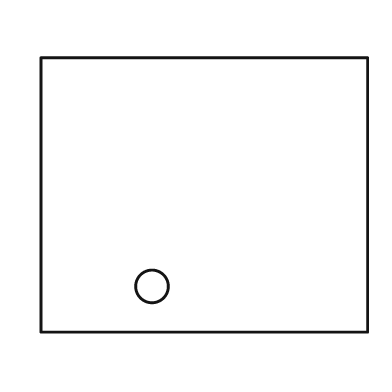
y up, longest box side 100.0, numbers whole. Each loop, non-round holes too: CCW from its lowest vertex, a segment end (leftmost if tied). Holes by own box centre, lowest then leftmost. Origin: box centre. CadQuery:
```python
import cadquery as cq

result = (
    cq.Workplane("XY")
    .moveTo(-50.0, -42.0)
    .lineTo(50.0, -42.0)
    .lineTo(50.0, 42.0)
    .lineTo(-50.0, 42.0)
    .close()
    .moveTo(-16.0, -28.0)
    .circle(5.0)
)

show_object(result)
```